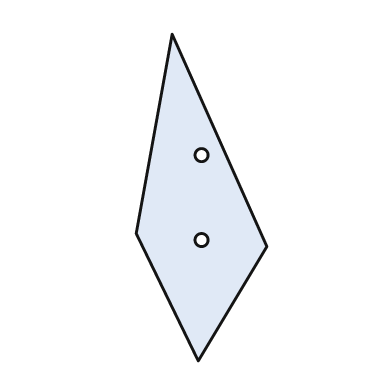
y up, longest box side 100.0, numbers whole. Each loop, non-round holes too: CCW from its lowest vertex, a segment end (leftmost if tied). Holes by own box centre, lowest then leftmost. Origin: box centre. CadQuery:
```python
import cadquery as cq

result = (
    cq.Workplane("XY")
    .moveTo(-1.0, -50.0)
    .lineTo(20.0, -15.0)
    .lineTo(-9.0, 50.0)
    .lineTo(-20.0, -11.0)
    .close()
    .moveTo(0.0, -13.0)
    .circle(2.0)
    .moveTo(0.0, 13.0)
    .circle(2.0)
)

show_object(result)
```